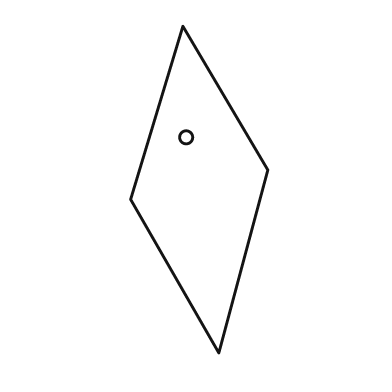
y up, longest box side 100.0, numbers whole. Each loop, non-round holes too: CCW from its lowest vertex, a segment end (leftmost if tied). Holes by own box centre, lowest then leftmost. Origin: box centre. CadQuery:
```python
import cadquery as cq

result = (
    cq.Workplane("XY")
    .moveTo(6.0, -50.0)
    .lineTo(21.0, 6.0)
    .lineTo(-5.0, 50.0)
    .lineTo(-21.0, -3.0)
    .close()
    .moveTo(-4.0, 16.0)
    .circle(2.0)
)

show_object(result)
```